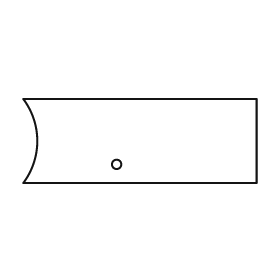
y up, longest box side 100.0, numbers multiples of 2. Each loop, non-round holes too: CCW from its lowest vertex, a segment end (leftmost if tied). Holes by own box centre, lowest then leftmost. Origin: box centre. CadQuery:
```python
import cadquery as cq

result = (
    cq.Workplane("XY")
    .moveTo(-50.0, -18.0)
    .lineTo(50.0, -18.0)
    .lineTo(50.0, 18.0)
    .lineTo(-50.0, 18.0)
    .threePointArc((-44.0, 0.0), (-50.0, -18.0))
    .close()
    .moveTo(-10.0, -10.0)
    .circle(2.0)
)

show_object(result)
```